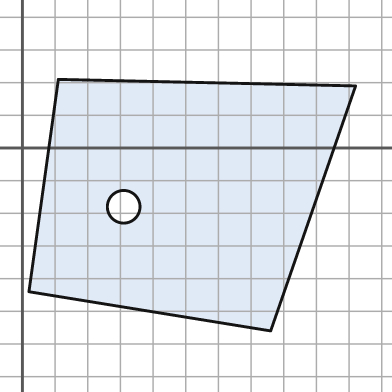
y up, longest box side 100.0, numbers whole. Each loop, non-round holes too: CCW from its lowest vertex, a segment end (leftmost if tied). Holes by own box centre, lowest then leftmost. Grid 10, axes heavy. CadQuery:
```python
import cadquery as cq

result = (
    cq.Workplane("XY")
    .moveTo(76.0, -56.0)
    .lineTo(102.0, 19.0)
    .lineTo(11.0, 21.0)
    .lineTo(2.0, -44.0)
    .close()
    .moveTo(31.0, -18.0)
    .circle(5.0)
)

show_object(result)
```